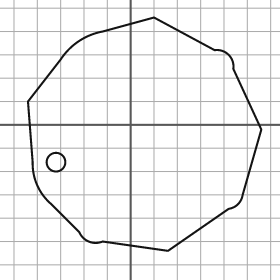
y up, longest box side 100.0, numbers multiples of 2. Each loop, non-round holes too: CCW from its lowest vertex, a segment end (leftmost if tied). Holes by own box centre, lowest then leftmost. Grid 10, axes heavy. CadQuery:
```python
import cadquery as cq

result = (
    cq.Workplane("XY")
    .moveTo(16.0, -54.0)
    .lineTo(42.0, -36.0)
    .threePointArc((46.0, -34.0), (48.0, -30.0))
    .lineTo(56.0, -2.0)
    .lineTo(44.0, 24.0)
    .threePointArc((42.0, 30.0), (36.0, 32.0))
    .lineTo(10.0, 46.0)
    .lineTo(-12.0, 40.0)
    .threePointArc((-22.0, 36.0), (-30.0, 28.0))
    .lineTo(-44.0, 10.0)
    .lineTo(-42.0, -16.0)
    .threePointArc((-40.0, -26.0), (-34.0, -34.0))
    .lineTo(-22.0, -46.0)
    .threePointArc((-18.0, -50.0), (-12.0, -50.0))
    .close()
    .moveTo(-32.0, -16.0)
    .circle(4.0)
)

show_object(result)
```